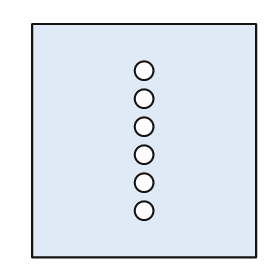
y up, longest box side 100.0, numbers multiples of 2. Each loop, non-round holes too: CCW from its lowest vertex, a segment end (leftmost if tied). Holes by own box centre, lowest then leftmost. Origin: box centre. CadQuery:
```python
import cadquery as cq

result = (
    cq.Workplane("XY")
    .moveTo(-48.0, -50.0)
    .lineTo(48.0, -50.0)
    .lineTo(48.0, 50.0)
    .lineTo(-48.0, 50.0)
    .close()
    .moveTo(0.0, -30.0)
    .circle(4.0)
    .moveTo(0.0, -18.0)
    .circle(4.0)
    .moveTo(0.0, -6.0)
    .circle(4.0)
    .moveTo(0.0, 6.0)
    .circle(4.0)
    .moveTo(0.0, 18.0)
    .circle(4.0)
    .moveTo(0.0, 30.0)
    .circle(4.0)
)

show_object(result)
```